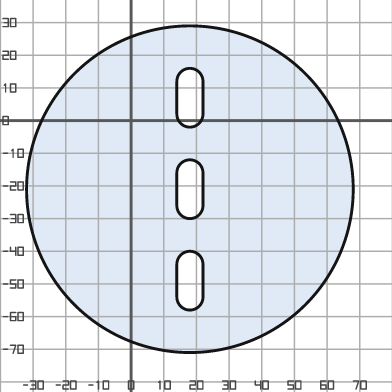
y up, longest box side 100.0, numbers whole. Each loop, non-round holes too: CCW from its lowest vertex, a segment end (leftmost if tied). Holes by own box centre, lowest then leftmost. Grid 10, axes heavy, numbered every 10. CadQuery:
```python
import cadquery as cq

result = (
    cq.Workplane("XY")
    .moveTo(18.0, -21.0)
    .circle(50.0)
    .moveTo(14.0, -54.0)
    .threePointArc((18.0, -58.0), (22.0, -54.0))
    .lineTo(22.0, -44.0)
    .threePointArc((18.0, -40.0), (14.0, -44.0))
    .close()
    .moveTo(14.0, -26.0)
    .threePointArc((18.0, -30.0), (22.0, -26.0))
    .lineTo(22.0, -16.0)
    .threePointArc((18.0, -12.0), (14.0, -16.0))
    .close()
    .moveTo(14.0, 2.0)
    .threePointArc((18.0, -2.0), (22.0, 2.0))
    .lineTo(22.0, 12.0)
    .threePointArc((18.0, 16.0), (14.0, 12.0))
    .close()
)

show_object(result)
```